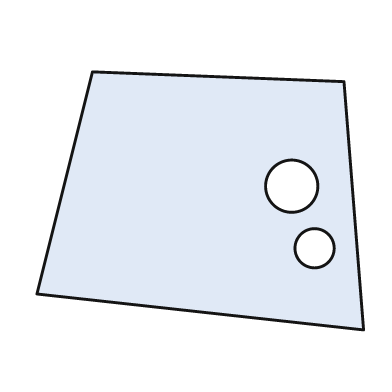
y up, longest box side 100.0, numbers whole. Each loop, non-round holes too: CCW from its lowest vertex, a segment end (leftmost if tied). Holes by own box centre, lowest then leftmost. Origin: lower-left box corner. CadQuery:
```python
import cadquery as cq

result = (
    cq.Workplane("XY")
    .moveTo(100.0, 0.0)
    .lineTo(94.0, 76.0)
    .lineTo(17.0, 79.0)
    .lineTo(0.0, 11.0)
    .close()
    .moveTo(85.0, 25.0)
    .circle(6.0)
    .moveTo(78.0, 44.0)
    .circle(8.0)
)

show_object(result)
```